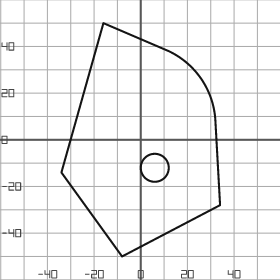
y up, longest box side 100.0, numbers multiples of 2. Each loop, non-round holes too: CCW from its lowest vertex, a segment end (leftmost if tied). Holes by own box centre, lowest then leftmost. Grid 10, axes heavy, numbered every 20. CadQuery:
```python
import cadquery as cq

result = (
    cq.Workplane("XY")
    .moveTo(-8.0, -50.0)
    .lineTo(34.0, -28.0)
    .lineTo(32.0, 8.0)
    .threePointArc((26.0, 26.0), (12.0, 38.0))
    .lineTo(-16.0, 50.0)
    .lineTo(-34.0, -14.0)
    .close()
    .moveTo(6.0, -12.0)
    .circle(6.0)
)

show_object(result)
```